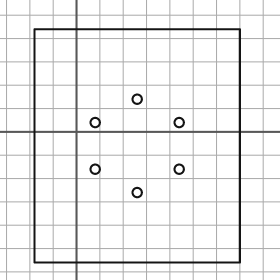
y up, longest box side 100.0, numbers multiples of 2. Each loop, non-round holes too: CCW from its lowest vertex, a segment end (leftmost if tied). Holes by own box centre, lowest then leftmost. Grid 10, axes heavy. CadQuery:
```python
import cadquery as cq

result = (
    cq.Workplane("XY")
    .moveTo(-18.0, -56.0)
    .lineTo(70.0, -56.0)
    .lineTo(70.0, 44.0)
    .lineTo(-18.0, 44.0)
    .close()
    .moveTo(26.0, -26.0)
    .circle(2.0)
    .moveTo(8.0, -16.0)
    .circle(2.0)
    .moveTo(44.0, -16.0)
    .circle(2.0)
    .moveTo(8.0, 4.0)
    .circle(2.0)
    .moveTo(44.0, 4.0)
    .circle(2.0)
    .moveTo(26.0, 14.0)
    .circle(2.0)
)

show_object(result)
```